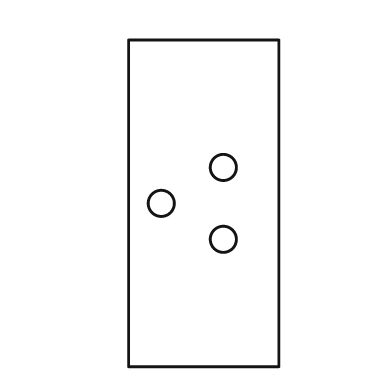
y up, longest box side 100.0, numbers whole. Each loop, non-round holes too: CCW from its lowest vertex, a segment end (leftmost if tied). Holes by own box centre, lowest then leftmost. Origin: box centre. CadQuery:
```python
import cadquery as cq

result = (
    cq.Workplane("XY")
    .moveTo(-23.0, -50.0)
    .lineTo(23.0, -50.0)
    .lineTo(23.0, 50.0)
    .lineTo(-23.0, 50.0)
    .close()
    .moveTo(6.0, -11.0)
    .circle(4.0)
    .moveTo(-13.0, 0.0)
    .circle(4.0)
    .moveTo(6.0, 11.0)
    .circle(4.0)
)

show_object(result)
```